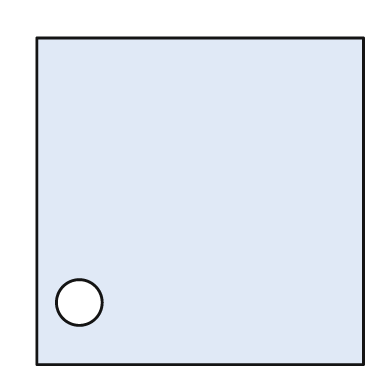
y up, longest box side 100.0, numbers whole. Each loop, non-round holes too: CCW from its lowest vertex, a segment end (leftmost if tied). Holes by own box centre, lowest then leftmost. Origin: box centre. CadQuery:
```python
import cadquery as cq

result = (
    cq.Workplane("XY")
    .moveTo(-50.0, -50.0)
    .lineTo(50.0, -50.0)
    .lineTo(50.0, 50.0)
    .lineTo(-50.0, 50.0)
    .close()
    .moveTo(-37.0, -31.0)
    .circle(7.0)
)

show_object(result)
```